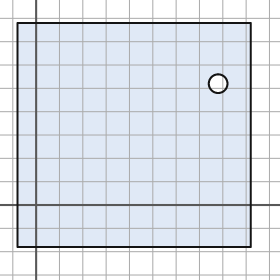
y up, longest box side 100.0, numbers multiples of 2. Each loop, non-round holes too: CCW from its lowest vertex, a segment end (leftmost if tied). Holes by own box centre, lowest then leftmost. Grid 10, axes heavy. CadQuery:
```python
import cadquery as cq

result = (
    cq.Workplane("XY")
    .moveTo(-8.0, -18.0)
    .lineTo(92.0, -18.0)
    .lineTo(92.0, 78.0)
    .lineTo(-8.0, 78.0)
    .close()
    .moveTo(78.0, 52.0)
    .circle(4.0)
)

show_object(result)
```